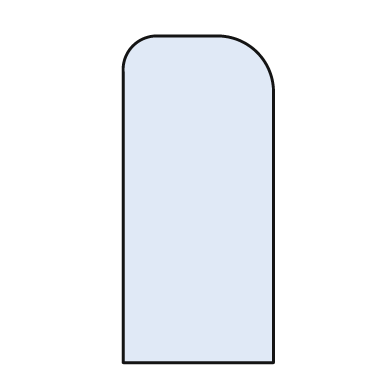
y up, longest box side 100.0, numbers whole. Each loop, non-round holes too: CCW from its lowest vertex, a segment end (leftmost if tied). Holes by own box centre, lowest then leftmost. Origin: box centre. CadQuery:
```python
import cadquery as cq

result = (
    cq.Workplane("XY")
    .moveTo(-23.0, -50.0)
    .lineTo(23.0, -50.0)
    .lineTo(23.0, 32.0)
    .threePointArc((18.0, 45.0), (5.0, 50.0))
    .lineTo(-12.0, 50.0)
    .threePointArc((-20.0, 47.0), (-23.0, 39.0))
    .close()
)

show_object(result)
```